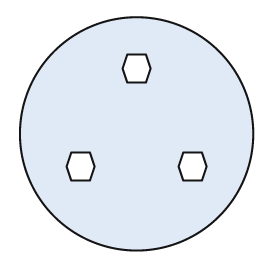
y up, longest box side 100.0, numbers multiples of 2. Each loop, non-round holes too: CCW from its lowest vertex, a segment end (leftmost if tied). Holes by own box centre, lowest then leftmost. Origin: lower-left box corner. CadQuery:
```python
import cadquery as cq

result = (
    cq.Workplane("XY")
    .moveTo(50.0, 50.0)
    .circle(50.0)
    .moveTo(22.0, 30.0)
    .lineTo(30.0, 30.0)
    .lineTo(32.0, 36.0)
    .lineTo(30.0, 42.0)
    .lineTo(22.0, 42.0)
    .lineTo(20.0, 36.0)
    .close()
    .moveTo(70.0, 30.0)
    .lineTo(78.0, 30.0)
    .lineTo(80.0, 36.0)
    .lineTo(78.0, 42.0)
    .lineTo(70.0, 42.0)
    .lineTo(68.0, 36.0)
    .close()
    .moveTo(46.0, 72.0)
    .lineTo(54.0, 72.0)
    .lineTo(56.0, 78.0)
    .lineTo(54.0, 84.0)
    .lineTo(46.0, 84.0)
    .lineTo(44.0, 78.0)
    .close()
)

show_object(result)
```